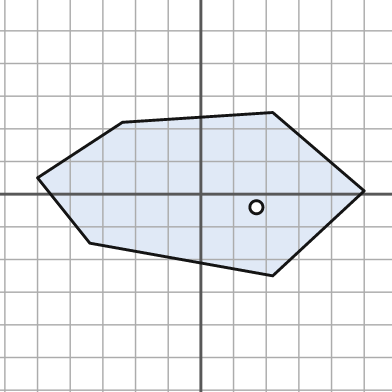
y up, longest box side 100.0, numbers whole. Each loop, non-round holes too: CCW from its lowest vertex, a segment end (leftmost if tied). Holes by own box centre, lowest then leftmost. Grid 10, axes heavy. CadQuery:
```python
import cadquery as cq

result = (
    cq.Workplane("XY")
    .moveTo(22.0, -25.0)
    .lineTo(50.0, 1.0)
    .lineTo(22.0, 25.0)
    .lineTo(-24.0, 22.0)
    .lineTo(-50.0, 5.0)
    .lineTo(-34.0, -15.0)
    .close()
    .moveTo(17.0, -4.0)
    .circle(2.0)
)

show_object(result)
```